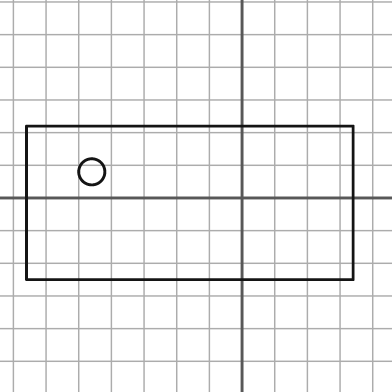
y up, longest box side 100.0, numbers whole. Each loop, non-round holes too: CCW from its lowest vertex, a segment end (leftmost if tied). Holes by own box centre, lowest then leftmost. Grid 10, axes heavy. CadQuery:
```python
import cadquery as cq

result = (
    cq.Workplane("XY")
    .moveTo(-66.0, -25.0)
    .lineTo(34.0, -25.0)
    .lineTo(34.0, 22.0)
    .lineTo(-66.0, 22.0)
    .close()
    .moveTo(-46.0, 8.0)
    .circle(4.0)
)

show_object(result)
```